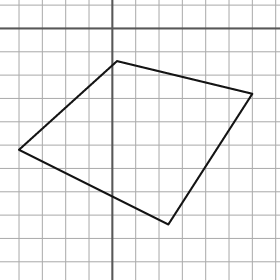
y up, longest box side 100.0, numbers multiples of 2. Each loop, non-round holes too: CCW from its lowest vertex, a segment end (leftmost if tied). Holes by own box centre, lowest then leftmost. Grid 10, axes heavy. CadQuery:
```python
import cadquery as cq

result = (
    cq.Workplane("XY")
    .moveTo(24.0, -84.0)
    .lineTo(60.0, -28.0)
    .lineTo(2.0, -14.0)
    .lineTo(-40.0, -52.0)
    .close()
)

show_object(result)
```